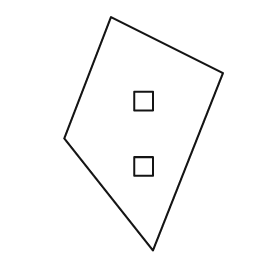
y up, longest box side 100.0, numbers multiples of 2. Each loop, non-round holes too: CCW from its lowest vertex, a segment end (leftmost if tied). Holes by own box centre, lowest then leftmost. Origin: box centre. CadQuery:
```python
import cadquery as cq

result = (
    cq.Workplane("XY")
    .moveTo(4.0, -50.0)
    .lineTo(34.0, 26.0)
    .lineTo(-14.0, 50.0)
    .lineTo(-34.0, -2.0)
    .close()
    .moveTo(-4.0, -18.0)
    .lineTo(4.0, -18.0)
    .lineTo(4.0, -10.0)
    .lineTo(-4.0, -10.0)
    .close()
    .moveTo(-4.0, 10.0)
    .lineTo(4.0, 10.0)
    .lineTo(4.0, 18.0)
    .lineTo(-4.0, 18.0)
    .close()
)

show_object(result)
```